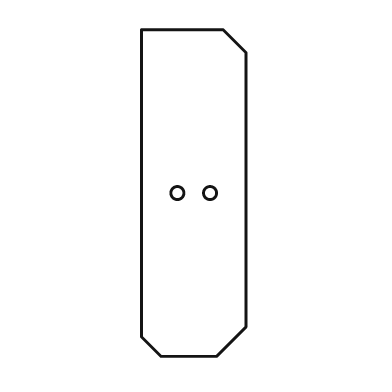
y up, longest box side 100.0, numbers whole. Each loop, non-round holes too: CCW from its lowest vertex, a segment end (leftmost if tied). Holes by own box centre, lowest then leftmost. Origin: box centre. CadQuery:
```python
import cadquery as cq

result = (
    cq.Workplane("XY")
    .moveTo(-10.0, -50.0)
    .lineTo(7.0, -50.0)
    .lineTo(16.0, -41.0)
    .lineTo(16.0, 43.0)
    .lineTo(9.0, 50.0)
    .lineTo(-16.0, 50.0)
    .lineTo(-16.0, -44.0)
    .close()
    .moveTo(-5.0, 0.0)
    .circle(2.0)
    .moveTo(5.0, 0.0)
    .circle(2.0)
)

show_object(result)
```